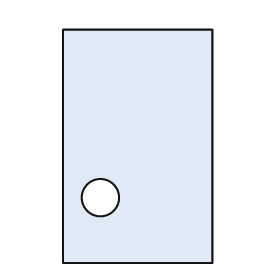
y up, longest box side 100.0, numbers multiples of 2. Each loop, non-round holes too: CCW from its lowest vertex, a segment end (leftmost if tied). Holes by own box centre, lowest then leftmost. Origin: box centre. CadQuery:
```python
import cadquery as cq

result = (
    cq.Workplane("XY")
    .moveTo(-32.0, -50.0)
    .lineTo(32.0, -50.0)
    .lineTo(32.0, 50.0)
    .lineTo(-32.0, 50.0)
    .close()
    .moveTo(-16.0, -22.0)
    .circle(8.0)
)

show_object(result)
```